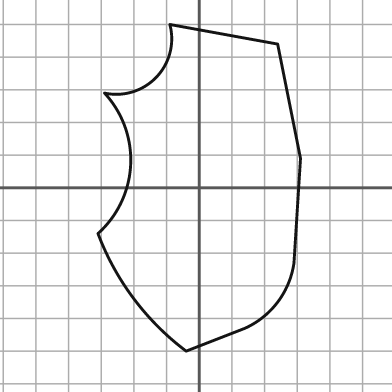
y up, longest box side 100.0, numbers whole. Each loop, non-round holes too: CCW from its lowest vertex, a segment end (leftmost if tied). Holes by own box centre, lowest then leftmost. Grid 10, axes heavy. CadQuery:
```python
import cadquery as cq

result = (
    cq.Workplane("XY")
    .moveTo(-4.0, -50.0)
    .lineTo(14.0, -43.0)
    .threePointArc((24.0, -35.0), (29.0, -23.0))
    .lineTo(31.0, 9.0)
    .lineTo(24.0, 44.0)
    .lineTo(-9.0, 50.0)
    .threePointArc((-13.0, 34.0), (-29.0, 29.0))
    .threePointArc((-21.0, 7.0), (-31.0, -14.0))
    .threePointArc((-20.0, -34.0), (-4.0, -50.0))
    .close()
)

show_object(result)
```